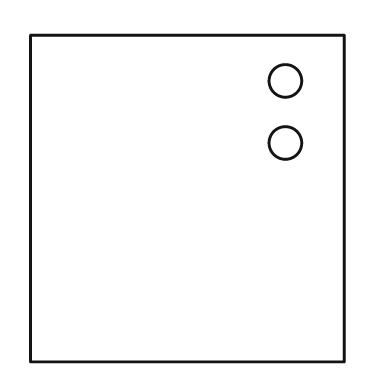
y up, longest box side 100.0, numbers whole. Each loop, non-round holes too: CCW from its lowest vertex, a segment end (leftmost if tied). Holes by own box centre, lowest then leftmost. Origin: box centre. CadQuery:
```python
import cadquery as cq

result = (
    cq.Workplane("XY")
    .moveTo(-48.0, -50.0)
    .lineTo(48.0, -50.0)
    .lineTo(48.0, 50.0)
    .lineTo(-48.0, 50.0)
    .close()
    .moveTo(30.0, 17.0)
    .circle(5.0)
    .moveTo(30.0, 36.0)
    .circle(5.0)
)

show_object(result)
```